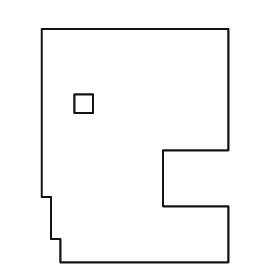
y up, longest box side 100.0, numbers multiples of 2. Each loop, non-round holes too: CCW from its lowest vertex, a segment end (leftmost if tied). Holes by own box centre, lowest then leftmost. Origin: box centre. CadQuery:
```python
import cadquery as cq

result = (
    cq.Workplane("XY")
    .moveTo(-32.0, -50.0)
    .lineTo(40.0, -50.0)
    .lineTo(40.0, -26.0)
    .lineTo(12.0, -26.0)
    .lineTo(12.0, -2.0)
    .lineTo(40.0, -2.0)
    .lineTo(40.0, 50.0)
    .lineTo(-40.0, 50.0)
    .lineTo(-40.0, -22.0)
    .lineTo(-36.0, -22.0)
    .lineTo(-36.0, -40.0)
    .lineTo(-32.0, -40.0)
    .close()
    .moveTo(-26.0, 14.0)
    .lineTo(-18.0, 14.0)
    .lineTo(-18.0, 22.0)
    .lineTo(-26.0, 22.0)
    .close()
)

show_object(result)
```